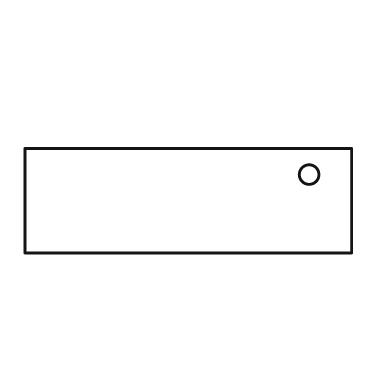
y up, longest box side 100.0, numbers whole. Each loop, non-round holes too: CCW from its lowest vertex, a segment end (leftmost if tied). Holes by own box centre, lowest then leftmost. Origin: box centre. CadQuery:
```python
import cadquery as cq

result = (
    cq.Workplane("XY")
    .moveTo(-50.0, -16.0)
    .lineTo(50.0, -16.0)
    .lineTo(50.0, 16.0)
    .lineTo(-50.0, 16.0)
    .close()
    .moveTo(37.0, 8.0)
    .circle(3.0)
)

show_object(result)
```